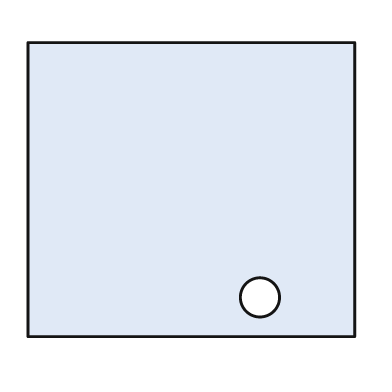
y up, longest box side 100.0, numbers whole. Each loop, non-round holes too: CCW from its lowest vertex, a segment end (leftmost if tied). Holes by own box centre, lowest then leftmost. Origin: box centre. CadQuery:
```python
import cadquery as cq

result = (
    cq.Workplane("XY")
    .moveTo(-50.0, -45.0)
    .lineTo(50.0, -45.0)
    .lineTo(50.0, 45.0)
    .lineTo(-50.0, 45.0)
    .close()
    .moveTo(21.0, -33.0)
    .circle(6.0)
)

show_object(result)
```